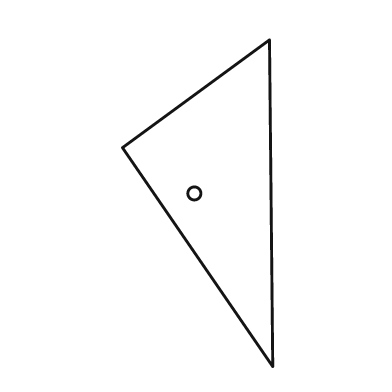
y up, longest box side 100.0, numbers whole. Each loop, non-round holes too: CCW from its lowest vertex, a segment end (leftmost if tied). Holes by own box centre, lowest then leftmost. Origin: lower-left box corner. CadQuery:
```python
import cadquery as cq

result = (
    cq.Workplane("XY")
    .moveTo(46.0, 0.0)
    .lineTo(45.0, 100.0)
    .lineTo(0.0, 67.0)
    .close()
    .moveTo(22.0, 53.0)
    .circle(2.0)
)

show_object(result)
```